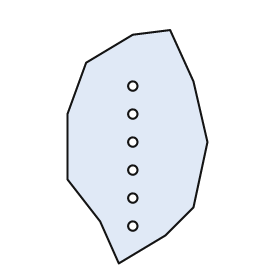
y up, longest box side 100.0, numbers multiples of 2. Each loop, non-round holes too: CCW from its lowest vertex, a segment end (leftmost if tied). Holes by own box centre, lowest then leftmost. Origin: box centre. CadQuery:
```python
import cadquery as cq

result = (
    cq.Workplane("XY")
    .moveTo(-8.0, -50.0)
    .lineTo(12.0, -38.0)
    .lineTo(24.0, -26.0)
    .lineTo(30.0, 2.0)
    .lineTo(24.0, 28.0)
    .lineTo(14.0, 50.0)
    .lineTo(-2.0, 48.0)
    .lineTo(-22.0, 36.0)
    .lineTo(-30.0, 14.0)
    .lineTo(-30.0, -14.0)
    .lineTo(-16.0, -32.0)
    .close()
    .moveTo(-2.0, -34.0)
    .circle(2.0)
    .moveTo(-2.0, -22.0)
    .circle(2.0)
    .moveTo(-2.0, -10.0)
    .circle(2.0)
    .moveTo(-2.0, 2.0)
    .circle(2.0)
    .moveTo(-2.0, 14.0)
    .circle(2.0)
    .moveTo(-2.0, 26.0)
    .circle(2.0)
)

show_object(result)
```